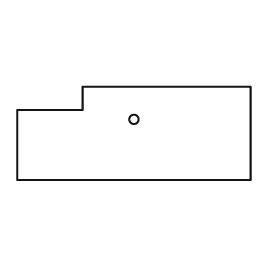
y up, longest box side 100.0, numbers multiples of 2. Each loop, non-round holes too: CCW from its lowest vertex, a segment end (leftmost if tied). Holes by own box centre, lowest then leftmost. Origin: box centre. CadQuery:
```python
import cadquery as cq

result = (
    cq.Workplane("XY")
    .moveTo(-50.0, -20.0)
    .lineTo(50.0, -20.0)
    .lineTo(50.0, 20.0)
    .lineTo(-22.0, 20.0)
    .lineTo(-22.0, 10.0)
    .lineTo(-50.0, 10.0)
    .close()
    .moveTo(0.0, 6.0)
    .circle(2.0)
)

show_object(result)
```